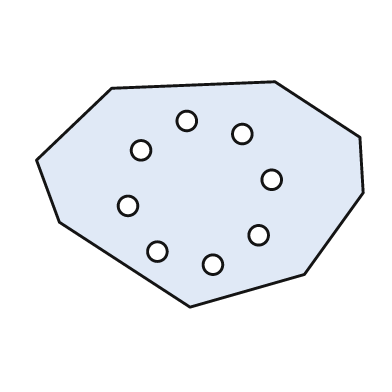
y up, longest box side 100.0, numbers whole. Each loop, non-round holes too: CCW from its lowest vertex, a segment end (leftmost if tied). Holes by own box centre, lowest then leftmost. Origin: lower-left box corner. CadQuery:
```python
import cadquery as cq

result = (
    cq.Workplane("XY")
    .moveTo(47.0, 0.0)
    .lineTo(82.0, 10.0)
    .lineTo(100.0, 35.0)
    .lineTo(99.0, 52.0)
    .lineTo(73.0, 69.0)
    .lineTo(23.0, 67.0)
    .lineTo(0.0, 45.0)
    .lineTo(7.0, 26.0)
    .close()
    .moveTo(54.0, 13.0)
    .circle(3.0)
    .moveTo(37.0, 17.0)
    .circle(3.0)
    .moveTo(68.0, 22.0)
    .circle(3.0)
    .moveTo(28.0, 31.0)
    .circle(3.0)
    .moveTo(72.0, 39.0)
    .circle(3.0)
    .moveTo(32.0, 48.0)
    .circle(3.0)
    .moveTo(63.0, 53.0)
    .circle(3.0)
    .moveTo(46.0, 57.0)
    .circle(3.0)
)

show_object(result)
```